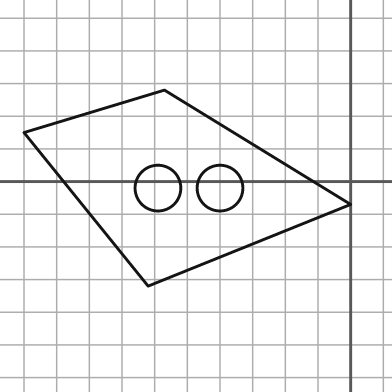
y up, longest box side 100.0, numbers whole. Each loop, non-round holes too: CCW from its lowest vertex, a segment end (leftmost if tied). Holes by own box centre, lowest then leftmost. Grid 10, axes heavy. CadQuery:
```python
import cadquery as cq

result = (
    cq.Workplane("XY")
    .moveTo(-62.0, -32.0)
    .lineTo(0.0, -7.0)
    .lineTo(-57.0, 28.0)
    .lineTo(-100.0, 15.0)
    .close()
    .moveTo(-59.0, -2.0)
    .circle(7.0)
    .moveTo(-40.0, -2.0)
    .circle(7.0)
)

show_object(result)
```